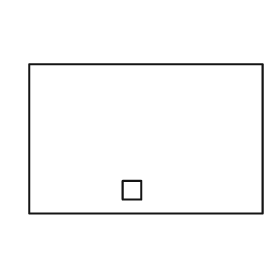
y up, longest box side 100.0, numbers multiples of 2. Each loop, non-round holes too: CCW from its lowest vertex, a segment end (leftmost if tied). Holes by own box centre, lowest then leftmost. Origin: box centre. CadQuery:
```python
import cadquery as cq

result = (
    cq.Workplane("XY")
    .moveTo(-50.0, -32.0)
    .lineTo(50.0, -32.0)
    .lineTo(50.0, 32.0)
    .lineTo(-50.0, 32.0)
    .close()
    .moveTo(-10.0, -26.0)
    .lineTo(-2.0, -26.0)
    .lineTo(-2.0, -18.0)
    .lineTo(-10.0, -18.0)
    .close()
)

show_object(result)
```